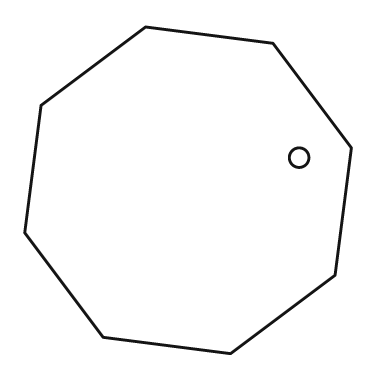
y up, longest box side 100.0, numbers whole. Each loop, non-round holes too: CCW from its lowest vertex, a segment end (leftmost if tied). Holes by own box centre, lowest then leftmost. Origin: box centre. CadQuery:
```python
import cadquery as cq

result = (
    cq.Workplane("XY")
    .moveTo(13.0, -50.0)
    .lineTo(45.0, -26.0)
    .lineTo(50.0, 13.0)
    .lineTo(26.0, 45.0)
    .lineTo(-13.0, 50.0)
    .lineTo(-45.0, 26.0)
    .lineTo(-50.0, -13.0)
    .lineTo(-26.0, -45.0)
    .close()
    .moveTo(34.0, 10.0)
    .circle(3.0)
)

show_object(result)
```